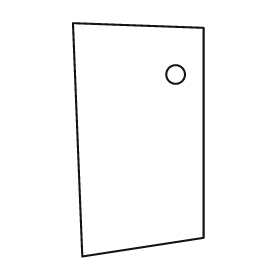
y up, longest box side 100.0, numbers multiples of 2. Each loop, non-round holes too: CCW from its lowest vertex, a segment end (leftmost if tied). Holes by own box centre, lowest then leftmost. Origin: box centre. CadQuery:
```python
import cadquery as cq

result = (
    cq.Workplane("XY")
    .moveTo(-24.0, -50.0)
    .lineTo(28.0, -42.0)
    .lineTo(28.0, 48.0)
    .lineTo(-28.0, 50.0)
    .close()
    .moveTo(16.0, 28.0)
    .circle(4.0)
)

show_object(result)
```